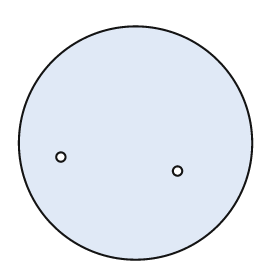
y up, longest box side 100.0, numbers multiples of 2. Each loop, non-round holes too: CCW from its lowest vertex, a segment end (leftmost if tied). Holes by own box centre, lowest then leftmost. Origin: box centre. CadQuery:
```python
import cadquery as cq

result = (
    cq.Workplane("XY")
    .moveTo(0.0, 0.0)
    .circle(50.0)
    .moveTo(18.0, -12.0)
    .circle(2.0)
    .moveTo(-32.0, -6.0)
    .circle(2.0)
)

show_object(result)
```